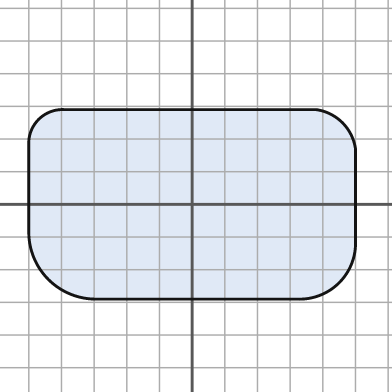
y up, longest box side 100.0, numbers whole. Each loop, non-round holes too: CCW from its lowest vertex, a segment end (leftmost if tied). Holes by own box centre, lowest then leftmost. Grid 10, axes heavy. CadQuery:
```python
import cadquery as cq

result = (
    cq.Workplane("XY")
    .moveTo(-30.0, -29.0)
    .lineTo(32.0, -29.0)
    .threePointArc((45.0, -24.0), (50.0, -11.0))
    .lineTo(50.0, 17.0)
    .threePointArc((46.0, 25.0), (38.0, 29.0))
    .lineTo(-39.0, 29.0)
    .threePointArc((-47.0, 26.0), (-50.0, 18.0))
    .lineTo(-50.0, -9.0)
    .threePointArc((-44.0, -23.0), (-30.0, -29.0))
    .close()
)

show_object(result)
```